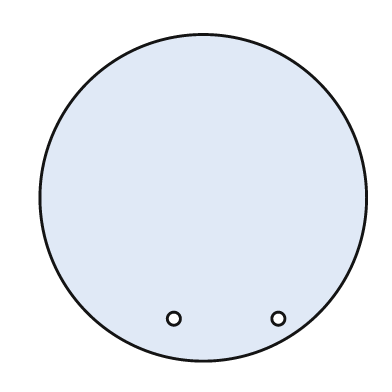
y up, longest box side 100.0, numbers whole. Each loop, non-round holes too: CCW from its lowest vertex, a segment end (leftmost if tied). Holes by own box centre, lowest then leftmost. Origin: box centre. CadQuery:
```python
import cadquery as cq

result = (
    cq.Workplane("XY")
    .moveTo(0.0, 0.0)
    .circle(50.0)
    .moveTo(-9.0, -37.0)
    .circle(2.0)
    .moveTo(23.0, -37.0)
    .circle(2.0)
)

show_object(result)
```